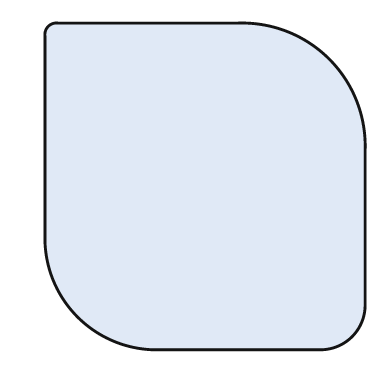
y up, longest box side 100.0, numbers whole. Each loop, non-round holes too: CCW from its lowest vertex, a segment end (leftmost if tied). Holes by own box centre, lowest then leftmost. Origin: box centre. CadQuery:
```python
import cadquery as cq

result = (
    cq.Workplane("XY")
    .moveTo(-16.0, -50.0)
    .lineTo(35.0, -50.0)
    .threePointArc((45.0, -46.0), (49.0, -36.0))
    .lineTo(49.0, 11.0)
    .threePointArc((38.0, 39.0), (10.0, 50.0))
    .lineTo(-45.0, 50.0)
    .threePointArc((-48.0, 49.0), (-49.0, 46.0))
    .lineTo(-49.0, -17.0)
    .threePointArc((-39.0, -40.0), (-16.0, -50.0))
    .close()
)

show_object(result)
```